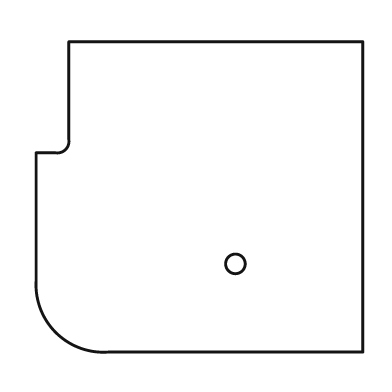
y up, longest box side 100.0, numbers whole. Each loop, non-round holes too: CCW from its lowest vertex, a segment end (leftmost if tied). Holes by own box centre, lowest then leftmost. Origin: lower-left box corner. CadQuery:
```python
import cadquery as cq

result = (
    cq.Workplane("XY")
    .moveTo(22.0, 0.0)
    .lineTo(100.0, 0.0)
    .lineTo(100.0, 95.0)
    .lineTo(10.0, 95.0)
    .lineTo(10.0, 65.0)
    .threePointArc((9.0, 62.0), (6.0, 61.0))
    .lineTo(0.0, 61.0)
    .lineTo(0.0, 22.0)
    .threePointArc((6.0, 6.0), (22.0, 0.0))
    .close()
    .moveTo(61.0, 27.0)
    .circle(3.0)
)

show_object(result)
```